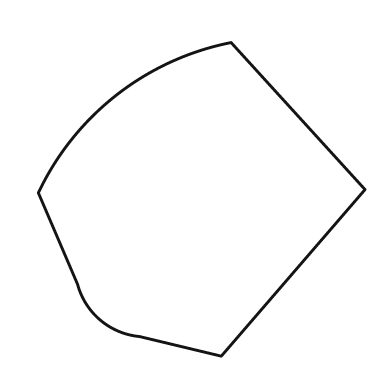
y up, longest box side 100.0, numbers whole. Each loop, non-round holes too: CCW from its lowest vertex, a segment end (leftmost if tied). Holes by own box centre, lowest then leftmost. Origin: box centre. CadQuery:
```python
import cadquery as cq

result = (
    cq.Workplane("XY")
    .moveTo(6.0, -48.0)
    .lineTo(50.0, 3.0)
    .lineTo(9.0, 48.0)
    .threePointArc((-26.0, 32.0), (-50.0, 2.0))
    .lineTo(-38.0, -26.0)
    .threePointArc((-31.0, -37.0), (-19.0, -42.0))
    .close()
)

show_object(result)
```